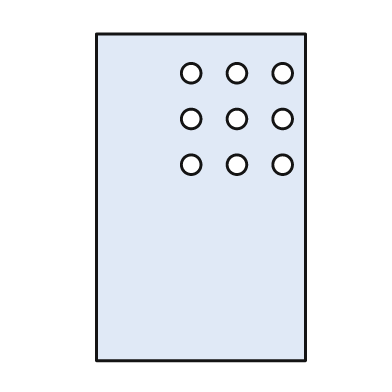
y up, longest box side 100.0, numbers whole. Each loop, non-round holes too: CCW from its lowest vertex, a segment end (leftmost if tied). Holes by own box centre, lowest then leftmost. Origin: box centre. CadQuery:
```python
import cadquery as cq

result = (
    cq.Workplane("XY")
    .moveTo(-32.0, -50.0)
    .lineTo(32.0, -50.0)
    .lineTo(32.0, 50.0)
    .lineTo(-32.0, 50.0)
    .close()
    .moveTo(-3.0, 10.0)
    .circle(3.0)
    .moveTo(11.0, 10.0)
    .circle(3.0)
    .moveTo(25.0, 10.0)
    .circle(3.0)
    .moveTo(-3.0, 24.0)
    .circle(3.0)
    .moveTo(11.0, 24.0)
    .circle(3.0)
    .moveTo(25.0, 24.0)
    .circle(3.0)
    .moveTo(-3.0, 38.0)
    .circle(3.0)
    .moveTo(11.0, 38.0)
    .circle(3.0)
    .moveTo(25.0, 38.0)
    .circle(3.0)
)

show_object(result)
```